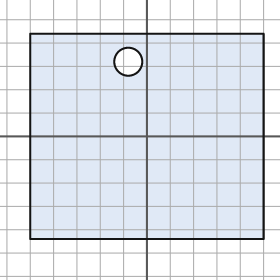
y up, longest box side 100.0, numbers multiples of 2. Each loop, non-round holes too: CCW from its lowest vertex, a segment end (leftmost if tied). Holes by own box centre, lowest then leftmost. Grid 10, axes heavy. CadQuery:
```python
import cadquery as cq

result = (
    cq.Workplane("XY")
    .moveTo(-50.0, -44.0)
    .lineTo(50.0, -44.0)
    .lineTo(50.0, 44.0)
    .lineTo(-50.0, 44.0)
    .close()
    .moveTo(-8.0, 32.0)
    .circle(6.0)
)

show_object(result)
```